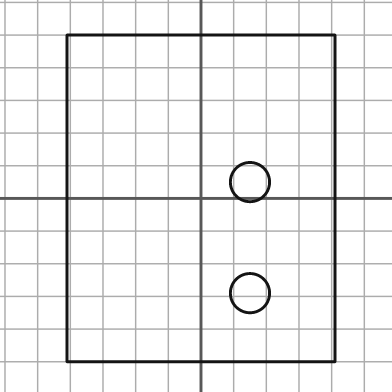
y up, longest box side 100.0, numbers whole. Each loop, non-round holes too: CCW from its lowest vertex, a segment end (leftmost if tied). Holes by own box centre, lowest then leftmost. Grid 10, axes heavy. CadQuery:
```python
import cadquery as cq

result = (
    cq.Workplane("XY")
    .moveTo(-41.0, -50.0)
    .lineTo(41.0, -50.0)
    .lineTo(41.0, 50.0)
    .lineTo(-41.0, 50.0)
    .close()
    .moveTo(15.0, -29.0)
    .circle(6.0)
    .moveTo(15.0, 5.0)
    .circle(6.0)
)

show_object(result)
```